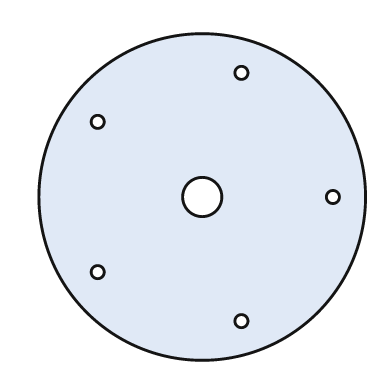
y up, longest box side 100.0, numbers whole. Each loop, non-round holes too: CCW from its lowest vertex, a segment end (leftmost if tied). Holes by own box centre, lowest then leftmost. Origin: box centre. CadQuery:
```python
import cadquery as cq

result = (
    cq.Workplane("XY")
    .moveTo(0.0, 0.0)
    .circle(50.0)
    .moveTo(12.0, -38.0)
    .circle(2.0)
    .moveTo(-32.0, -23.0)
    .circle(2.0)
    .moveTo(0.0, 0.0)
    .circle(6.0)
    .moveTo(40.0, 0.0)
    .circle(2.0)
    .moveTo(-32.0, 23.0)
    .circle(2.0)
    .moveTo(12.0, 38.0)
    .circle(2.0)
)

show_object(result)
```